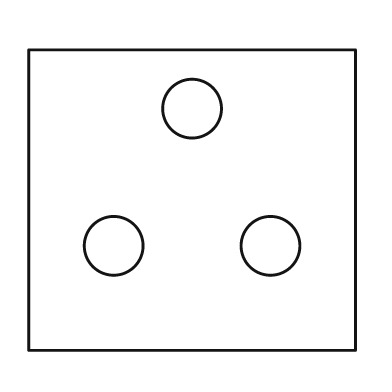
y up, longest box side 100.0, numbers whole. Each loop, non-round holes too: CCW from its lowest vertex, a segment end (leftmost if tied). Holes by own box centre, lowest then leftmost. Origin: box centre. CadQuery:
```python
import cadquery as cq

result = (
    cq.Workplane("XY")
    .moveTo(-50.0, -46.0)
    .lineTo(50.0, -46.0)
    .lineTo(50.0, 46.0)
    .lineTo(-50.0, 46.0)
    .close()
    .moveTo(-24.0, -14.0)
    .circle(9.0)
    .moveTo(24.0, -14.0)
    .circle(9.0)
    .moveTo(0.0, 28.0)
    .circle(9.0)
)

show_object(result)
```